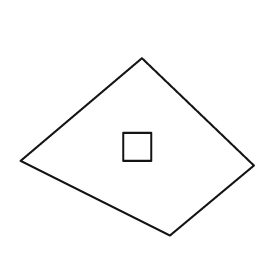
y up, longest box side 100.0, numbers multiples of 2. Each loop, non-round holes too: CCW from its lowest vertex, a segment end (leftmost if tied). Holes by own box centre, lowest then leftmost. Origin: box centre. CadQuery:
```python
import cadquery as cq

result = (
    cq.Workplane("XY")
    .moveTo(14.0, -38.0)
    .lineTo(50.0, -8.0)
    .lineTo(2.0, 38.0)
    .lineTo(-50.0, -6.0)
    .close()
    .moveTo(-6.0, -6.0)
    .lineTo(6.0, -6.0)
    .lineTo(6.0, 6.0)
    .lineTo(-6.0, 6.0)
    .close()
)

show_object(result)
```